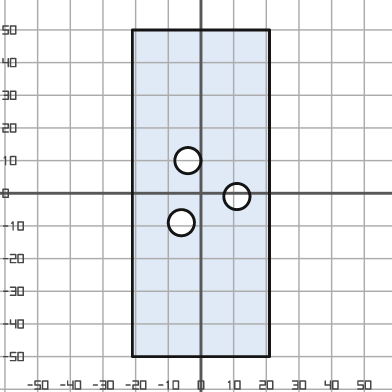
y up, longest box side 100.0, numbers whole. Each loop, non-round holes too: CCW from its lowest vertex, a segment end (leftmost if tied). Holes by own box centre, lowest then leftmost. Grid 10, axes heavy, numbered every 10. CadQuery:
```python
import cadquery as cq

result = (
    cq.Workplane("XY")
    .moveTo(-21.0, -50.0)
    .lineTo(21.0, -50.0)
    .lineTo(21.0, 50.0)
    .lineTo(-21.0, 50.0)
    .close()
    .moveTo(-6.0, -9.0)
    .circle(4.0)
    .moveTo(11.0, -1.0)
    .circle(4.0)
    .moveTo(-4.0, 10.0)
    .circle(4.0)
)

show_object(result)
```